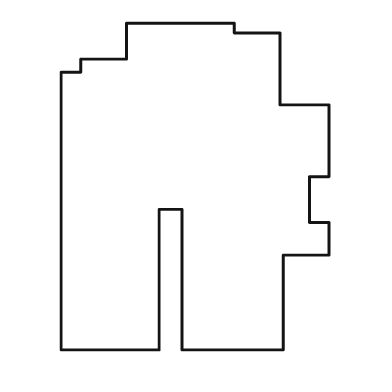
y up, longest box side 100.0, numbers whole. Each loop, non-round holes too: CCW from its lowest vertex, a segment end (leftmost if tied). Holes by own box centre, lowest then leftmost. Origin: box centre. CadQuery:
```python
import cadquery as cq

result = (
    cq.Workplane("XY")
    .moveTo(-41.0, -50.0)
    .lineTo(-11.0, -50.0)
    .lineTo(-11.0, -7.0)
    .lineTo(-4.0, -7.0)
    .lineTo(-4.0, -50.0)
    .lineTo(27.0, -50.0)
    .lineTo(27.0, -21.0)
    .lineTo(41.0, -21.0)
    .lineTo(41.0, -11.0)
    .lineTo(35.0, -11.0)
    .lineTo(35.0, 3.0)
    .lineTo(41.0, 3.0)
    .lineTo(41.0, 25.0)
    .lineTo(26.0, 25.0)
    .lineTo(26.0, 47.0)
    .lineTo(12.0, 47.0)
    .lineTo(12.0, 50.0)
    .lineTo(-21.0, 50.0)
    .lineTo(-21.0, 39.0)
    .lineTo(-35.0, 39.0)
    .lineTo(-35.0, 35.0)
    .lineTo(-41.0, 35.0)
    .close()
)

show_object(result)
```